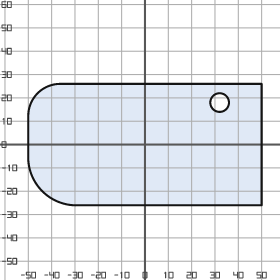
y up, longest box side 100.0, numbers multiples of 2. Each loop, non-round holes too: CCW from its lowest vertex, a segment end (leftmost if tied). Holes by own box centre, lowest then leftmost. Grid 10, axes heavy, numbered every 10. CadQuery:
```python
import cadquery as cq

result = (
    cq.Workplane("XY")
    .moveTo(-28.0, -26.0)
    .lineTo(50.0, -26.0)
    .lineTo(50.0, 26.0)
    .lineTo(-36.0, 26.0)
    .threePointArc((-46.0, 22.0), (-50.0, 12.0))
    .lineTo(-50.0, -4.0)
    .threePointArc((-44.0, -20.0), (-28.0, -26.0))
    .close()
    .moveTo(32.0, 18.0)
    .circle(4.0)
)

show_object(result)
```